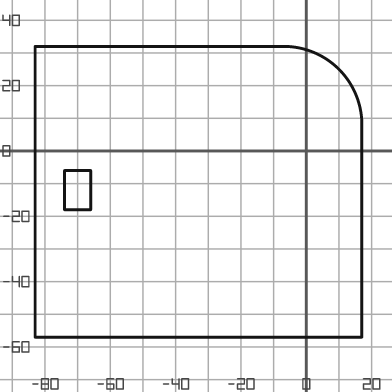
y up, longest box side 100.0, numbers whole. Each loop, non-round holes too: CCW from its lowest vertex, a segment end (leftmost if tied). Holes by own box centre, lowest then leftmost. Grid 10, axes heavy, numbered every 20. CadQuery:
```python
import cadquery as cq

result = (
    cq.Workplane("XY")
    .moveTo(-83.0, -57.0)
    .lineTo(17.0, -57.0)
    .lineTo(17.0, 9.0)
    .threePointArc((10.0, 25.0), (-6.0, 32.0))
    .lineTo(-83.0, 32.0)
    .close()
    .moveTo(-74.0, -18.0)
    .lineTo(-66.0, -18.0)
    .lineTo(-66.0, -6.0)
    .lineTo(-74.0, -6.0)
    .close()
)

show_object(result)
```